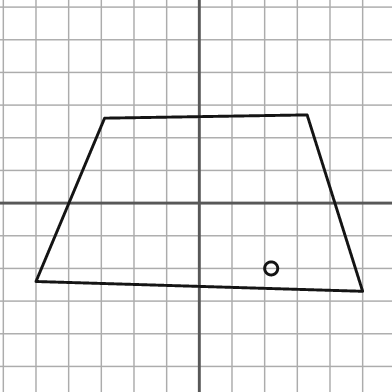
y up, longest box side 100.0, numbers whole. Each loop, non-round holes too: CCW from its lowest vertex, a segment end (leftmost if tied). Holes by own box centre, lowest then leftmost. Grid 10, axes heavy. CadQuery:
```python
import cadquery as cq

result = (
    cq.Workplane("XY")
    .moveTo(50.0, -27.0)
    .lineTo(33.0, 27.0)
    .lineTo(-29.0, 26.0)
    .lineTo(-50.0, -24.0)
    .close()
    .moveTo(22.0, -20.0)
    .circle(2.0)
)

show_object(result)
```